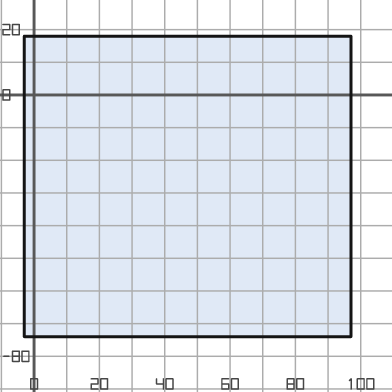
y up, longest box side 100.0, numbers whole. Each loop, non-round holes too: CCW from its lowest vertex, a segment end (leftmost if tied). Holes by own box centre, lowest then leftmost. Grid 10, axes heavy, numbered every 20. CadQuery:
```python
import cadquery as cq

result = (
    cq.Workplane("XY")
    .moveTo(-3.0, -74.0)
    .lineTo(97.0, -74.0)
    .lineTo(97.0, 18.0)
    .lineTo(-3.0, 18.0)
    .close()
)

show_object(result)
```